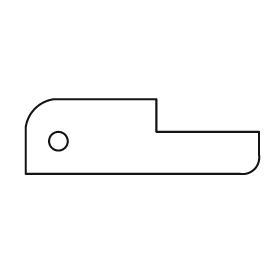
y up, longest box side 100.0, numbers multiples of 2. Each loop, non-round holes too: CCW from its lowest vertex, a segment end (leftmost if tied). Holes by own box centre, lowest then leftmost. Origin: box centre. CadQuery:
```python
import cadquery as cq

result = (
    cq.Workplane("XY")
    .moveTo(-50.0, -16.0)
    .lineTo(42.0, -16.0)
    .threePointArc((48.0, -14.0), (50.0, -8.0))
    .lineTo(50.0, 2.0)
    .lineTo(6.0, 2.0)
    .lineTo(6.0, 16.0)
    .lineTo(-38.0, 16.0)
    .threePointArc((-46.0, 12.0), (-50.0, 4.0))
    .close()
    .moveTo(-36.0, -2.0)
    .circle(4.0)
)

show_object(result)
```